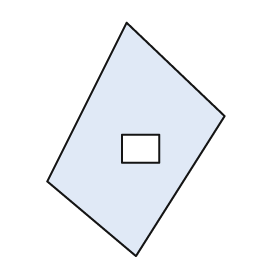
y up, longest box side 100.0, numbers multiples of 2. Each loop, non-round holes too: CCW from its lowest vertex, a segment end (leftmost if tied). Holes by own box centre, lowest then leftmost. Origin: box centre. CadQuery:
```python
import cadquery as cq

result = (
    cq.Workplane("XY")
    .moveTo(0.0, -50.0)
    .lineTo(38.0, 10.0)
    .lineTo(-4.0, 50.0)
    .lineTo(-38.0, -18.0)
    .close()
    .moveTo(-6.0, -10.0)
    .lineTo(10.0, -10.0)
    .lineTo(10.0, 2.0)
    .lineTo(-6.0, 2.0)
    .close()
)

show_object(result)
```